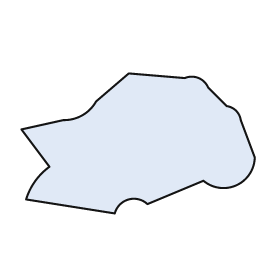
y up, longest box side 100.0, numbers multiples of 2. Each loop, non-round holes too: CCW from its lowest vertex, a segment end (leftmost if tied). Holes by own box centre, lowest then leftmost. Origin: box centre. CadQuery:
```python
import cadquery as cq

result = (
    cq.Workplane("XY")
    .moveTo(-10.0, -30.0)
    .threePointArc((-4.0, -24.0), (4.0, -26.0))
    .lineTo(28.0, -16.0)
    .threePointArc((42.0, -18.0), (50.0, -6.0))
    .lineTo(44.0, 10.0)
    .threePointArc((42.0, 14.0), (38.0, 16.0))
    .lineTo(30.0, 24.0)
    .threePointArc((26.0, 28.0), (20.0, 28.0))
    .lineTo(-4.0, 30.0)
    .lineTo(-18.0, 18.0)
    .threePointArc((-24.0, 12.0), (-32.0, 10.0))
    .lineTo(-50.0, 6.0)
    .lineTo(-38.0, -10.0)
    .threePointArc((-44.0, -16.0), (-48.0, -24.0))
    .close()
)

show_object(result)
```